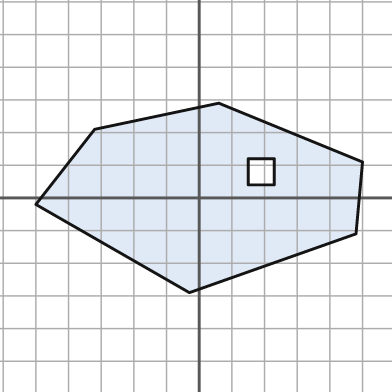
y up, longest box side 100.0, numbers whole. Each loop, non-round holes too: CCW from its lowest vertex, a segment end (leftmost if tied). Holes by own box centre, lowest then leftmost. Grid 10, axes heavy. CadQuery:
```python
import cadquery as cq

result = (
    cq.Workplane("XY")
    .moveTo(-3.0, -29.0)
    .lineTo(48.0, -11.0)
    .lineTo(50.0, 11.0)
    .lineTo(6.0, 29.0)
    .lineTo(-32.0, 21.0)
    .lineTo(-50.0, -2.0)
    .close()
    .moveTo(15.0, 4.0)
    .lineTo(23.0, 4.0)
    .lineTo(23.0, 12.0)
    .lineTo(15.0, 12.0)
    .close()
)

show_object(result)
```